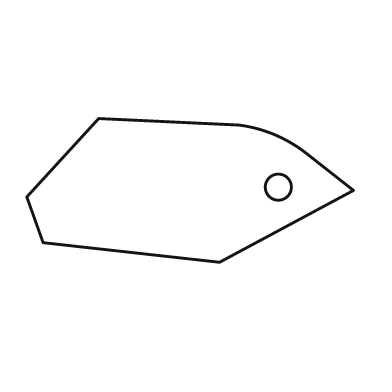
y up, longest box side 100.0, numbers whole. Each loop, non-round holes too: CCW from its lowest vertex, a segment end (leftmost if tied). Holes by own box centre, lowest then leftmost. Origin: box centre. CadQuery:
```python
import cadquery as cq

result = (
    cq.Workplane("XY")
    .moveTo(9.0, -22.0)
    .lineTo(50.0, 0.0)
    .lineTo(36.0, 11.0)
    .threePointArc((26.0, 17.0), (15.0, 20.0))
    .lineTo(-28.0, 22.0)
    .lineTo(-50.0, -2.0)
    .lineTo(-45.0, -16.0)
    .close()
    .moveTo(27.0, 1.0)
    .circle(4.0)
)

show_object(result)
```